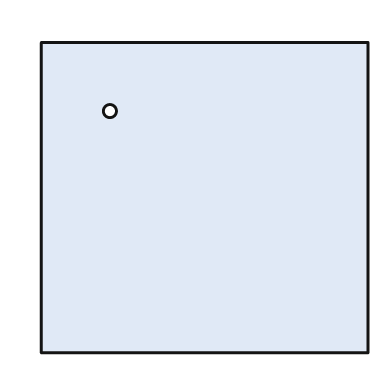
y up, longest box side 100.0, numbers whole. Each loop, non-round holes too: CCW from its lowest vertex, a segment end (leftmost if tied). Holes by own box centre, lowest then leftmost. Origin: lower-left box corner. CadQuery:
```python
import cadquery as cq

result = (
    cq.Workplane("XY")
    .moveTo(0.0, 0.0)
    .lineTo(100.0, 0.0)
    .lineTo(100.0, 95.0)
    .lineTo(0.0, 95.0)
    .close()
    .moveTo(21.0, 74.0)
    .circle(2.0)
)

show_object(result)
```